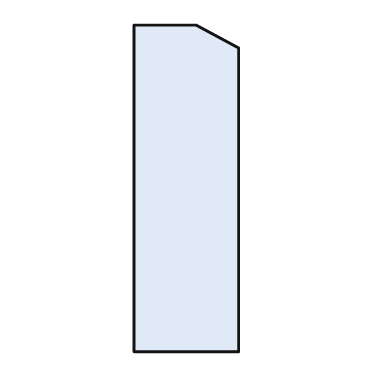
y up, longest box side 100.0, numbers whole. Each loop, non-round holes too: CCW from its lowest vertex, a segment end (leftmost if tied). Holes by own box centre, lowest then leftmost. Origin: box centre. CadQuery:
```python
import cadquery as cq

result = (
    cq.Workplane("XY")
    .moveTo(-16.0, -50.0)
    .lineTo(16.0, -50.0)
    .lineTo(16.0, 43.0)
    .lineTo(3.0, 50.0)
    .lineTo(-16.0, 50.0)
    .close()
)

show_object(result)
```